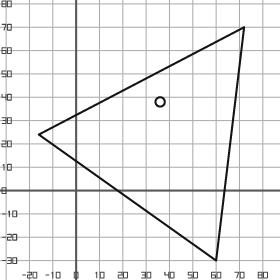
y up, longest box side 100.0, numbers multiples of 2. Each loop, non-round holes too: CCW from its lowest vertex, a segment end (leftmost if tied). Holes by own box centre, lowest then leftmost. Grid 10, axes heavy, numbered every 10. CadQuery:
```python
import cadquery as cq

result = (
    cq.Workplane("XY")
    .moveTo(60.0, -30.0)
    .lineTo(72.0, 70.0)
    .lineTo(-16.0, 24.0)
    .close()
    .moveTo(36.0, 38.0)
    .circle(2.0)
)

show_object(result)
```